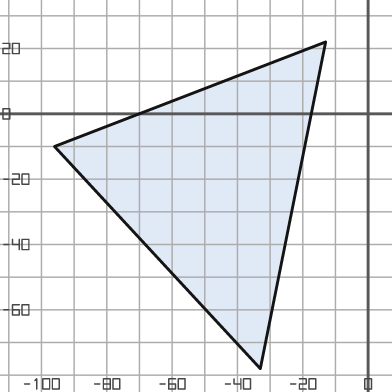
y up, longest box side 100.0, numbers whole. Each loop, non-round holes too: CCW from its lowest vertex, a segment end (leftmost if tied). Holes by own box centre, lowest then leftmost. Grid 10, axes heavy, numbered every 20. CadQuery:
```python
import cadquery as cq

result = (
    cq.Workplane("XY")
    .moveTo(-33.0, -78.0)
    .lineTo(-13.0, 22.0)
    .lineTo(-96.0, -10.0)
    .close()
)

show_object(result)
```